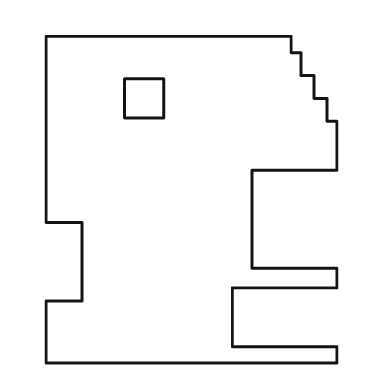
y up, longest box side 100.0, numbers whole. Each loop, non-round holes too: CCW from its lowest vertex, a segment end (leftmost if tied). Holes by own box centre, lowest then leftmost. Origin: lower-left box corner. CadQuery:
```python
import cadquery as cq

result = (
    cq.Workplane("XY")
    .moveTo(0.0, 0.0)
    .lineTo(89.0, 0.0)
    .lineTo(89.0, 5.0)
    .lineTo(57.0, 5.0)
    .lineTo(57.0, 23.0)
    .lineTo(89.0, 23.0)
    .lineTo(89.0, 29.0)
    .lineTo(63.0, 29.0)
    .lineTo(63.0, 59.0)
    .lineTo(89.0, 59.0)
    .lineTo(89.0, 74.0)
    .lineTo(86.0, 74.0)
    .lineTo(86.0, 81.0)
    .lineTo(82.0, 81.0)
    .lineTo(82.0, 88.0)
    .lineTo(78.0, 88.0)
    .lineTo(78.0, 95.0)
    .lineTo(75.0, 95.0)
    .lineTo(75.0, 100.0)
    .lineTo(0.0, 100.0)
    .lineTo(0.0, 43.0)
    .lineTo(11.0, 43.0)
    .lineTo(11.0, 19.0)
    .lineTo(0.0, 19.0)
    .close()
    .moveTo(24.0, 75.0)
    .lineTo(36.0, 75.0)
    .lineTo(36.0, 87.0)
    .lineTo(24.0, 87.0)
    .close()
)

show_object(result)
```